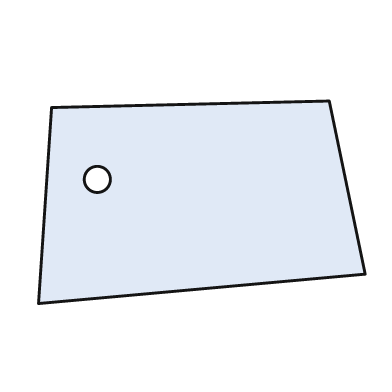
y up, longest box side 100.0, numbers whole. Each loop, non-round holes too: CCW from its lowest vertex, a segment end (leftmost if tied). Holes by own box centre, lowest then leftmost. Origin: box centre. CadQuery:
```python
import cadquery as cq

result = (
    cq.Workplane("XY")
    .moveTo(-50.0, -31.0)
    .lineTo(50.0, -22.0)
    .lineTo(39.0, 31.0)
    .lineTo(-46.0, 29.0)
    .close()
    .moveTo(-32.0, 7.0)
    .circle(4.0)
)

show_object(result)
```